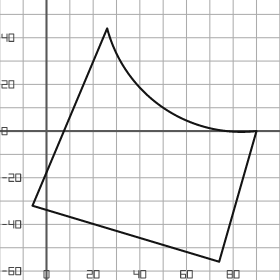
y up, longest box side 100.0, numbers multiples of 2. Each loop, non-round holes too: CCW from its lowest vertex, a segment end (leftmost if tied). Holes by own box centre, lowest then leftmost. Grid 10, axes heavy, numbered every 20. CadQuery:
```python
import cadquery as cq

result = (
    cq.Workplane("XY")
    .moveTo(74.0, -56.0)
    .lineTo(90.0, 0.0)
    .threePointArc((50.0, 10.0), (26.0, 44.0))
    .lineTo(-6.0, -32.0)
    .close()
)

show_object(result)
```